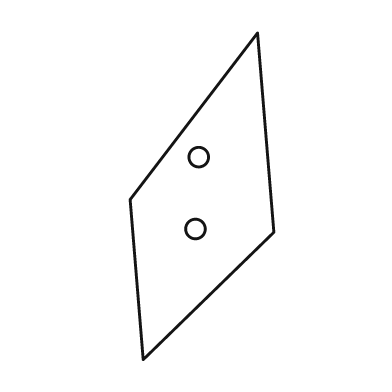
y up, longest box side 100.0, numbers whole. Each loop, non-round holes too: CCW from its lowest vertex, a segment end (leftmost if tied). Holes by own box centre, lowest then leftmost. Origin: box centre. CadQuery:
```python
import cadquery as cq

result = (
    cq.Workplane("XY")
    .moveTo(-18.0, -50.0)
    .lineTo(22.0, -11.0)
    .lineTo(17.0, 50.0)
    .lineTo(-22.0, -1.0)
    .close()
    .moveTo(-2.0, -10.0)
    .circle(3.0)
    .moveTo(-1.0, 12.0)
    .circle(3.0)
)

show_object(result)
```